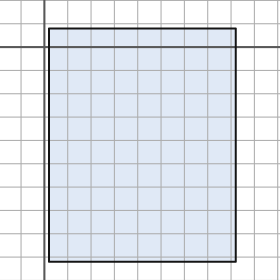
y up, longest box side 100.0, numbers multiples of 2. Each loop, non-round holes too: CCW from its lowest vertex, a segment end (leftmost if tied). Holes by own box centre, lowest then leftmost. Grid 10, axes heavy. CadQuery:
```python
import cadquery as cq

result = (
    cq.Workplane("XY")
    .moveTo(2.0, -92.0)
    .lineTo(82.0, -92.0)
    .lineTo(82.0, 8.0)
    .lineTo(2.0, 8.0)
    .close()
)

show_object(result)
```